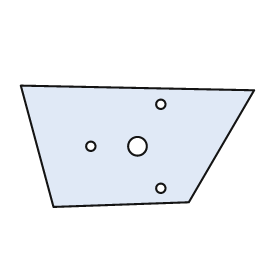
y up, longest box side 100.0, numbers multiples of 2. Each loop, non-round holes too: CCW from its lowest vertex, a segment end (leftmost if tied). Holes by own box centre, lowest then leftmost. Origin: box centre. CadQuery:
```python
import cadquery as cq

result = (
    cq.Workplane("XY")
    .moveTo(-36.0, -26.0)
    .lineTo(22.0, -24.0)
    .lineTo(50.0, 24.0)
    .lineTo(-50.0, 26.0)
    .close()
    .moveTo(10.0, -18.0)
    .circle(2.0)
    .moveTo(-20.0, 0.0)
    .circle(2.0)
    .moveTo(0.0, 0.0)
    .circle(4.0)
    .moveTo(10.0, 18.0)
    .circle(2.0)
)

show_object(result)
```